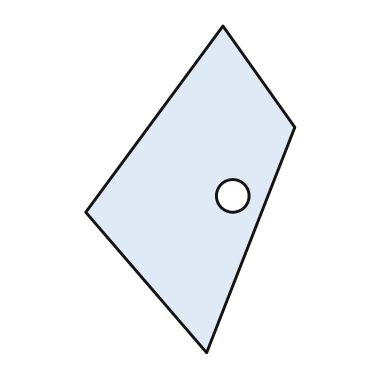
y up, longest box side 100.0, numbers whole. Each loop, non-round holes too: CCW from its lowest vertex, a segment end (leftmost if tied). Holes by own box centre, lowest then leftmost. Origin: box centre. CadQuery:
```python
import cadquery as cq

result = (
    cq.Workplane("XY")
    .moveTo(5.0, -50.0)
    .lineTo(32.0, 19.0)
    .lineTo(10.0, 50.0)
    .lineTo(-32.0, -7.0)
    .close()
    .moveTo(13.0, -2.0)
    .circle(5.0)
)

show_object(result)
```